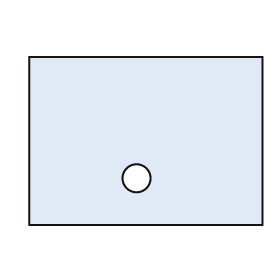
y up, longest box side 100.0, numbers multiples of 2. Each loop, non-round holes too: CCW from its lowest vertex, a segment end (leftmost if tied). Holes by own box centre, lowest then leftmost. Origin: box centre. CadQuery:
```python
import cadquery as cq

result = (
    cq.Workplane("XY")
    .moveTo(-50.0, -36.0)
    .lineTo(50.0, -36.0)
    .lineTo(50.0, 36.0)
    .lineTo(-50.0, 36.0)
    .close()
    .moveTo(-4.0, -16.0)
    .circle(6.0)
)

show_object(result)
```